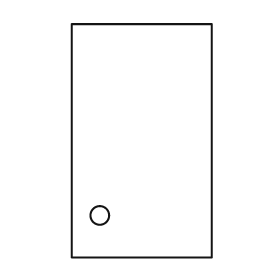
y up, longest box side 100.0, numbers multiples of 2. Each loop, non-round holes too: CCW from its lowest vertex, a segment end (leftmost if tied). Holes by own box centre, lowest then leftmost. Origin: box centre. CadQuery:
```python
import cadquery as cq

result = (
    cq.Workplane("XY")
    .moveTo(-30.0, -50.0)
    .lineTo(30.0, -50.0)
    .lineTo(30.0, 50.0)
    .lineTo(-30.0, 50.0)
    .close()
    .moveTo(-18.0, -32.0)
    .circle(4.0)
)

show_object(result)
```